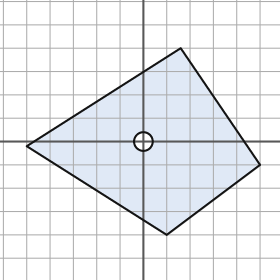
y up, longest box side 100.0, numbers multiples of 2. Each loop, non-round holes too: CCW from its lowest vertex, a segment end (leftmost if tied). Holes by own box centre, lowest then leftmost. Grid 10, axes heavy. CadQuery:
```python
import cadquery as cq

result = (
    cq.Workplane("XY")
    .moveTo(10.0, -40.0)
    .lineTo(50.0, -10.0)
    .lineTo(16.0, 40.0)
    .lineTo(-50.0, -2.0)
    .close()
    .moveTo(0.0, 0.0)
    .circle(4.0)
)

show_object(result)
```